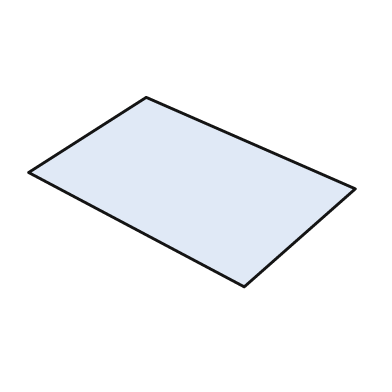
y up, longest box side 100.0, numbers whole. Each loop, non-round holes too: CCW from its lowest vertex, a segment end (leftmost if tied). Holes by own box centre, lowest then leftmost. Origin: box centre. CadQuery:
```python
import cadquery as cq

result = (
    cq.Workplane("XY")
    .moveTo(16.0, -29.0)
    .lineTo(50.0, 1.0)
    .lineTo(-14.0, 29.0)
    .lineTo(-50.0, 6.0)
    .close()
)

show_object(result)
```